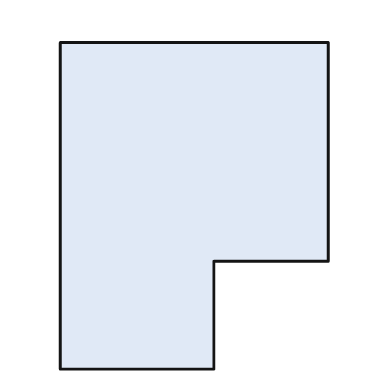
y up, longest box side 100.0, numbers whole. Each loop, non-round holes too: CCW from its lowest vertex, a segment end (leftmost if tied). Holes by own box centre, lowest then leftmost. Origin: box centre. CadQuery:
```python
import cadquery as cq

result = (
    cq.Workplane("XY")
    .moveTo(-41.0, -50.0)
    .lineTo(6.0, -50.0)
    .lineTo(6.0, -17.0)
    .lineTo(41.0, -17.0)
    .lineTo(41.0, 50.0)
    .lineTo(-41.0, 50.0)
    .close()
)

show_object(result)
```